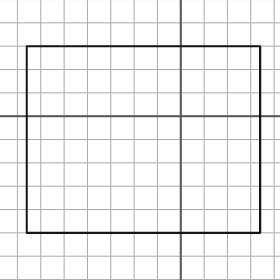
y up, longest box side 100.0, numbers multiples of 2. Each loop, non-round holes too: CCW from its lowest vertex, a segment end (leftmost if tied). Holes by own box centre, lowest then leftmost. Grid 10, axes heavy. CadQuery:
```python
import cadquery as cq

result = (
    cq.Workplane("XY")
    .moveTo(-66.0, -50.0)
    .lineTo(34.0, -50.0)
    .lineTo(34.0, 30.0)
    .lineTo(-66.0, 30.0)
    .close()
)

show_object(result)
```